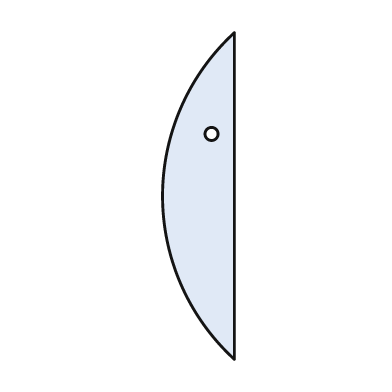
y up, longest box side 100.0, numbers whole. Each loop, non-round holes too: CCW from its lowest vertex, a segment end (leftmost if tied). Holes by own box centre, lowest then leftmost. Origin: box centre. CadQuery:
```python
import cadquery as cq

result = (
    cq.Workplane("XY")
    .moveTo(11.0, -50.0)
    .lineTo(11.0, 50.0)
    .threePointArc((-11.0, 0.0), (11.0, -50.0))
    .close()
    .moveTo(4.0, 19.0)
    .circle(2.0)
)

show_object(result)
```